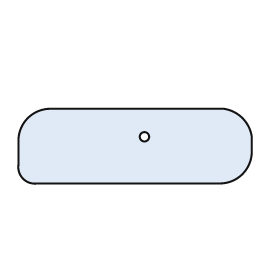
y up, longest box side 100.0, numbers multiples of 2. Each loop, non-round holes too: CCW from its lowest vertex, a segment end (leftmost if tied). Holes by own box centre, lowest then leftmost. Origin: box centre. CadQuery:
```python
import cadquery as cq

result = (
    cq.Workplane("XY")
    .moveTo(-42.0, -16.0)
    .lineTo(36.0, -16.0)
    .threePointArc((46.0, -12.0), (50.0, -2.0))
    .lineTo(50.0, 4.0)
    .threePointArc((46.0, 12.0), (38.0, 16.0))
    .lineTo(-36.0, 16.0)
    .threePointArc((-46.0, 12.0), (-50.0, 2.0))
    .lineTo(-50.0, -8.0)
    .threePointArc((-48.0, -14.0), (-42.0, -16.0))
    .close()
    .moveTo(4.0, 4.0)
    .circle(2.0)
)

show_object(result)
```